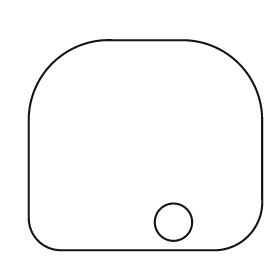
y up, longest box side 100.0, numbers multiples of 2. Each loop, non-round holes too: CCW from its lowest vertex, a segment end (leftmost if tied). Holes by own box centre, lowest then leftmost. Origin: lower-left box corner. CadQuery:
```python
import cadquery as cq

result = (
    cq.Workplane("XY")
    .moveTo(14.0, 0.0)
    .lineTo(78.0, 0.0)
    .threePointArc((94.0, 6.0), (100.0, 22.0))
    .lineTo(100.0, 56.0)
    .threePointArc((90.0, 80.0), (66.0, 90.0))
    .lineTo(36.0, 90.0)
    .threePointArc((10.0, 80.0), (0.0, 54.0))
    .lineTo(0.0, 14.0)
    .threePointArc((4.0, 4.0), (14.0, 0.0))
    .close()
    .moveTo(62.0, 12.0)
    .circle(8.0)
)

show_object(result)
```